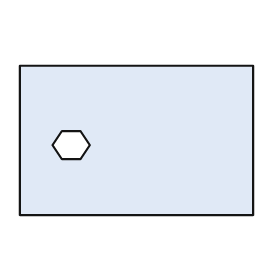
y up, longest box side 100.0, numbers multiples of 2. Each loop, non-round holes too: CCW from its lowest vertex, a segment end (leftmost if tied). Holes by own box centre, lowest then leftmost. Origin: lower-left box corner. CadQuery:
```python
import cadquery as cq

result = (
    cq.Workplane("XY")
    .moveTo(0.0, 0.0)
    .lineTo(100.0, 0.0)
    .lineTo(100.0, 64.0)
    .lineTo(0.0, 64.0)
    .close()
    .moveTo(18.0, 24.0)
    .lineTo(26.0, 24.0)
    .lineTo(30.0, 30.0)
    .lineTo(26.0, 36.0)
    .lineTo(18.0, 36.0)
    .lineTo(14.0, 30.0)
    .close()
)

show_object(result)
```